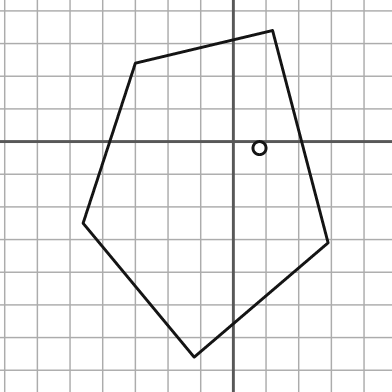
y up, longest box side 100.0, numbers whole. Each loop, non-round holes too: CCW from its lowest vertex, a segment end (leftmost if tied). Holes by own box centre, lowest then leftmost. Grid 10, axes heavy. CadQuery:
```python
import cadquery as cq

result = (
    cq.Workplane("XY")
    .moveTo(-12.0, -66.0)
    .lineTo(29.0, -31.0)
    .lineTo(12.0, 34.0)
    .lineTo(-30.0, 24.0)
    .lineTo(-46.0, -25.0)
    .close()
    .moveTo(8.0, -2.0)
    .circle(2.0)
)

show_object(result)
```